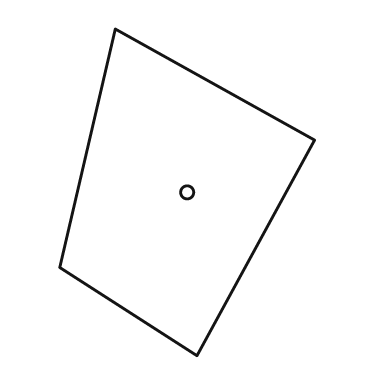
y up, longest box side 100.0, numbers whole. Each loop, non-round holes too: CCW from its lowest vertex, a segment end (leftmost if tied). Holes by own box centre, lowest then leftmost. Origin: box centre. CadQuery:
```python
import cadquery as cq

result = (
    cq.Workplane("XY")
    .moveTo(3.0, -50.0)
    .lineTo(39.0, 16.0)
    .lineTo(-22.0, 50.0)
    .lineTo(-39.0, -23.0)
    .close()
    .moveTo(0.0, 0.0)
    .circle(2.0)
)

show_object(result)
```